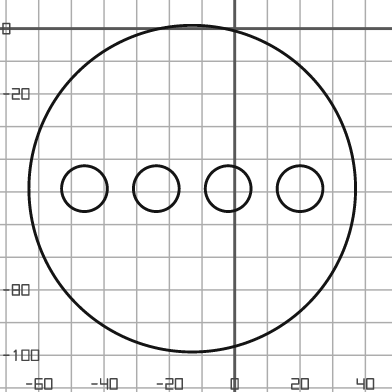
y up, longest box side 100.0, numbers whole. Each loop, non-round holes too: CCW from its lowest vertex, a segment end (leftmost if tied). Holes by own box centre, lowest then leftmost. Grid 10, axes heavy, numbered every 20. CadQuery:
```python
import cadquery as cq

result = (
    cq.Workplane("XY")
    .moveTo(-13.0, -49.0)
    .circle(50.0)
    .moveTo(-46.0, -49.0)
    .circle(7.0)
    .moveTo(-24.0, -49.0)
    .circle(7.0)
    .moveTo(-2.0, -49.0)
    .circle(7.0)
    .moveTo(20.0, -49.0)
    .circle(7.0)
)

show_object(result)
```